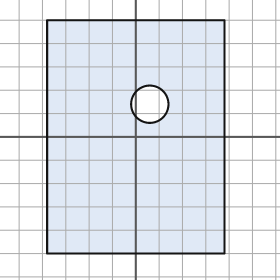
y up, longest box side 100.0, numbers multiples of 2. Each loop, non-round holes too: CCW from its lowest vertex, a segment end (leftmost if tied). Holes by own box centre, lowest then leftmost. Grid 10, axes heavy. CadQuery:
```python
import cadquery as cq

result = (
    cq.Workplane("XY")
    .moveTo(-38.0, -50.0)
    .lineTo(38.0, -50.0)
    .lineTo(38.0, 50.0)
    .lineTo(-38.0, 50.0)
    .close()
    .moveTo(6.0, 14.0)
    .circle(8.0)
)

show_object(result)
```